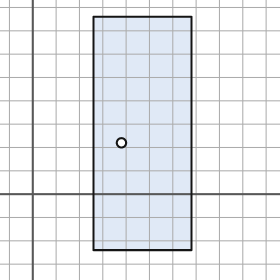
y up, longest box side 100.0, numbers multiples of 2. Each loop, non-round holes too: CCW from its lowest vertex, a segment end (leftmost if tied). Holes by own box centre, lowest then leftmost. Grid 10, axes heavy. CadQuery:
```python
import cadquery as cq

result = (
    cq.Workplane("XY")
    .moveTo(26.0, -24.0)
    .lineTo(68.0, -24.0)
    .lineTo(68.0, 76.0)
    .lineTo(26.0, 76.0)
    .close()
    .moveTo(38.0, 22.0)
    .circle(2.0)
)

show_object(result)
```